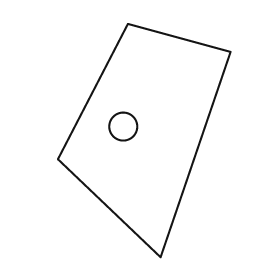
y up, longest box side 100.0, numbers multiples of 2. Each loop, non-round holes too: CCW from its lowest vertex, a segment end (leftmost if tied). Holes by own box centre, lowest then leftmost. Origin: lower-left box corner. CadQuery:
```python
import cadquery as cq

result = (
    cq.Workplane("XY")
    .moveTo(44.0, 0.0)
    .lineTo(74.0, 88.0)
    .lineTo(30.0, 100.0)
    .lineTo(0.0, 42.0)
    .close()
    .moveTo(28.0, 56.0)
    .circle(6.0)
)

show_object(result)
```